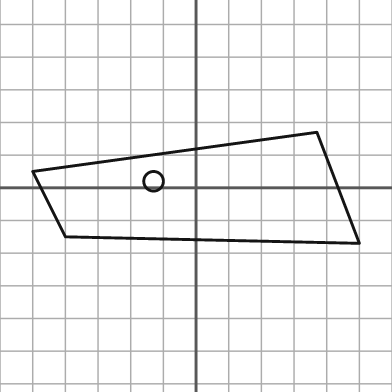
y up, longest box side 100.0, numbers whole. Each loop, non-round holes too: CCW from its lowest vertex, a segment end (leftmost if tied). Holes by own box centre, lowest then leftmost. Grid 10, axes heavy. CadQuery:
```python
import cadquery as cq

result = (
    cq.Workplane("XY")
    .moveTo(50.0, -17.0)
    .lineTo(37.0, 17.0)
    .lineTo(-50.0, 5.0)
    .lineTo(-40.0, -15.0)
    .close()
    .moveTo(-13.0, 2.0)
    .circle(3.0)
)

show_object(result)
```